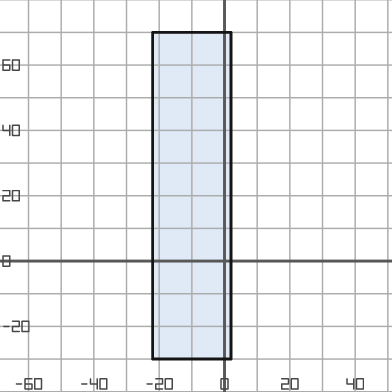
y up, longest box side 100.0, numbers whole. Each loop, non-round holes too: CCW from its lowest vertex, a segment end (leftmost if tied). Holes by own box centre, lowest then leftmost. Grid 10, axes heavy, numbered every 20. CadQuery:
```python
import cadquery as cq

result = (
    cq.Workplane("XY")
    .moveTo(-22.0, -30.0)
    .lineTo(2.0, -30.0)
    .lineTo(2.0, 70.0)
    .lineTo(-22.0, 70.0)
    .close()
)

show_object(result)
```